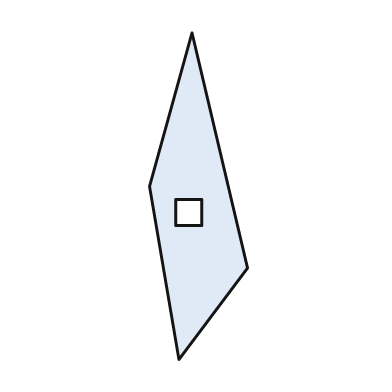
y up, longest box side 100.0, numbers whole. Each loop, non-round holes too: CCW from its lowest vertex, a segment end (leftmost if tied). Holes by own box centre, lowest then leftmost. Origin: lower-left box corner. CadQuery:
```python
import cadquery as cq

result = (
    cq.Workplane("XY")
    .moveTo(9.0, 0.0)
    .lineTo(30.0, 28.0)
    .lineTo(13.0, 100.0)
    .lineTo(0.0, 53.0)
    .close()
    .moveTo(8.0, 41.0)
    .lineTo(16.0, 41.0)
    .lineTo(16.0, 49.0)
    .lineTo(8.0, 49.0)
    .close()
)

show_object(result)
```